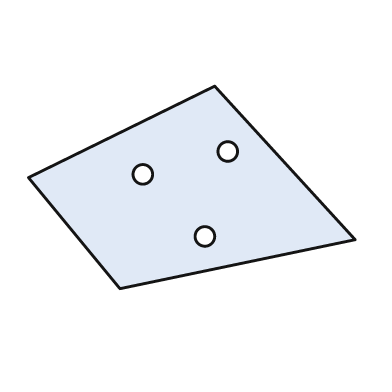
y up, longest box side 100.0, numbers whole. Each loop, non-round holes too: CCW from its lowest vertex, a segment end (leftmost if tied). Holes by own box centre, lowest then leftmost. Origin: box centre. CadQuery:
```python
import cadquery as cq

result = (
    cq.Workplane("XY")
    .moveTo(-22.0, -31.0)
    .lineTo(50.0, -16.0)
    .lineTo(7.0, 31.0)
    .lineTo(-50.0, 3.0)
    .close()
    .moveTo(4.0, -15.0)
    .circle(3.0)
    .moveTo(-15.0, 4.0)
    .circle(3.0)
    .moveTo(11.0, 11.0)
    .circle(3.0)
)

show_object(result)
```